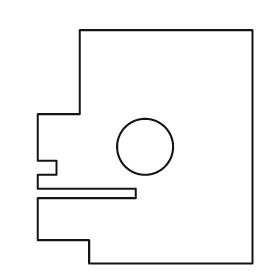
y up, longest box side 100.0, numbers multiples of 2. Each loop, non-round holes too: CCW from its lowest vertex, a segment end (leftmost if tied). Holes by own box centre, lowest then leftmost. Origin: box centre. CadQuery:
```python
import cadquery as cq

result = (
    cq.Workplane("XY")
    .moveTo(-24.0, -50.0)
    .lineTo(46.0, -50.0)
    .lineTo(46.0, 50.0)
    .lineTo(-28.0, 50.0)
    .lineTo(-28.0, 14.0)
    .lineTo(-46.0, 14.0)
    .lineTo(-46.0, -6.0)
    .lineTo(-38.0, -6.0)
    .lineTo(-38.0, -12.0)
    .lineTo(-46.0, -12.0)
    .lineTo(-46.0, -18.0)
    .lineTo(-4.0, -18.0)
    .lineTo(-4.0, -22.0)
    .lineTo(-46.0, -22.0)
    .lineTo(-46.0, -40.0)
    .lineTo(-24.0, -40.0)
    .close()
    .moveTo(0.0, 0.0)
    .circle(12.0)
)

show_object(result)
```